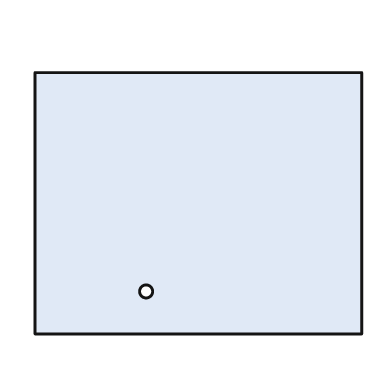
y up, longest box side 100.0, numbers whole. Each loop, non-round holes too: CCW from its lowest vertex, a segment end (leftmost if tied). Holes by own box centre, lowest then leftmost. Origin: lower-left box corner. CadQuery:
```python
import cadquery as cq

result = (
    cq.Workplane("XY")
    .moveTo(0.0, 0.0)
    .lineTo(100.0, 0.0)
    .lineTo(100.0, 80.0)
    .lineTo(0.0, 80.0)
    .close()
    .moveTo(34.0, 13.0)
    .circle(2.0)
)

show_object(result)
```